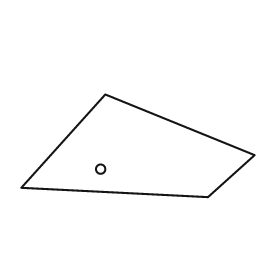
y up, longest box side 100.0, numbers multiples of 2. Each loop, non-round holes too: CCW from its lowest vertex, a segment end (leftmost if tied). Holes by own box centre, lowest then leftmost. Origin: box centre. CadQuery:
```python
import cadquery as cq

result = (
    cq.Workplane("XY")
    .moveTo(30.0, -22.0)
    .lineTo(50.0, -4.0)
    .lineTo(-14.0, 22.0)
    .lineTo(-50.0, -18.0)
    .close()
    .moveTo(-16.0, -10.0)
    .circle(2.0)
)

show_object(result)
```